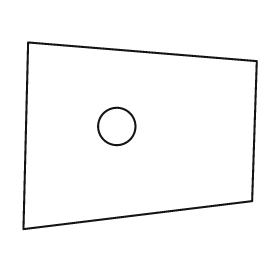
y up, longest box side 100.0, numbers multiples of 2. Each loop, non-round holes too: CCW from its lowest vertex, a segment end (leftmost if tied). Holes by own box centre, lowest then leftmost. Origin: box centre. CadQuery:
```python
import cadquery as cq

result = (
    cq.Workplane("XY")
    .moveTo(-50.0, -40.0)
    .lineTo(48.0, -28.0)
    .lineTo(50.0, 32.0)
    .lineTo(-48.0, 40.0)
    .close()
    .moveTo(-10.0, 4.0)
    .circle(8.0)
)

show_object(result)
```